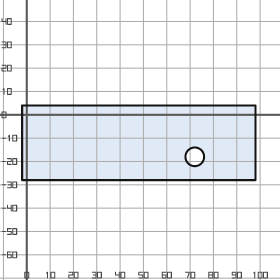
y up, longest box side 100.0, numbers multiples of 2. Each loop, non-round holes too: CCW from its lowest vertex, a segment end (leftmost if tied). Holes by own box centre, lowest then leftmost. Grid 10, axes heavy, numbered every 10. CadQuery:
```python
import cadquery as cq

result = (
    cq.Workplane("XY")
    .moveTo(-2.0, -28.0)
    .lineTo(98.0, -28.0)
    .lineTo(98.0, 4.0)
    .lineTo(-2.0, 4.0)
    .close()
    .moveTo(72.0, -18.0)
    .circle(4.0)
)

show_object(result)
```